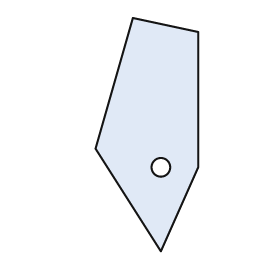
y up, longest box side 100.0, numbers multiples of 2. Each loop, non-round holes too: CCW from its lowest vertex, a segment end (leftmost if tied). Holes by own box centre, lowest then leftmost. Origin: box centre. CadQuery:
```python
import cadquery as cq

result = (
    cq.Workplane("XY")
    .moveTo(6.0, -50.0)
    .lineTo(22.0, -14.0)
    .lineTo(22.0, 44.0)
    .lineTo(-6.0, 50.0)
    .lineTo(-22.0, -6.0)
    .close()
    .moveTo(6.0, -14.0)
    .circle(4.0)
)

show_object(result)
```